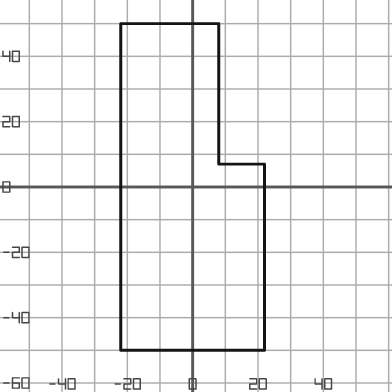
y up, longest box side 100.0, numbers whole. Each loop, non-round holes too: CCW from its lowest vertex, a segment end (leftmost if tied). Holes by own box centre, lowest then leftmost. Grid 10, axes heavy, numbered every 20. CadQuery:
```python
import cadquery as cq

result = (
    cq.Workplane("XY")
    .moveTo(-22.0, -50.0)
    .lineTo(22.0, -50.0)
    .lineTo(22.0, 7.0)
    .lineTo(8.0, 7.0)
    .lineTo(8.0, 50.0)
    .lineTo(-22.0, 50.0)
    .close()
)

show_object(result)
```